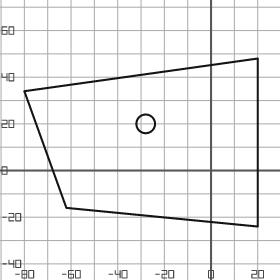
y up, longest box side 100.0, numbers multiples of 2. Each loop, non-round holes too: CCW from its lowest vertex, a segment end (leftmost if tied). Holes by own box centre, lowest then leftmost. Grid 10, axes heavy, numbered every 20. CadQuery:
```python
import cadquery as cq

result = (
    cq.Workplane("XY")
    .moveTo(20.0, -24.0)
    .lineTo(20.0, 48.0)
    .lineTo(-80.0, 34.0)
    .lineTo(-62.0, -16.0)
    .close()
    .moveTo(-28.0, 20.0)
    .circle(4.0)
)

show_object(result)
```